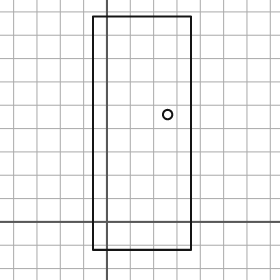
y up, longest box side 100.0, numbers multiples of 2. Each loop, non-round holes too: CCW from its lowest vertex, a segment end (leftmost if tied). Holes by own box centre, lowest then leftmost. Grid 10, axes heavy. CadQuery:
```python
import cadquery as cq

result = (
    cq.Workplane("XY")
    .moveTo(-6.0, -12.0)
    .lineTo(36.0, -12.0)
    .lineTo(36.0, 88.0)
    .lineTo(-6.0, 88.0)
    .close()
    .moveTo(26.0, 46.0)
    .circle(2.0)
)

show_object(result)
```